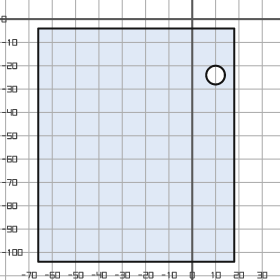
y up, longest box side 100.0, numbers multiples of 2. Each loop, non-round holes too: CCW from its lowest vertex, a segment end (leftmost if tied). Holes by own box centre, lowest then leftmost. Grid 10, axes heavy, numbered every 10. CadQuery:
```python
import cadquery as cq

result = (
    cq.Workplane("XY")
    .moveTo(-66.0, -104.0)
    .lineTo(18.0, -104.0)
    .lineTo(18.0, -4.0)
    .lineTo(-66.0, -4.0)
    .close()
    .moveTo(10.0, -24.0)
    .circle(4.0)
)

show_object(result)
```